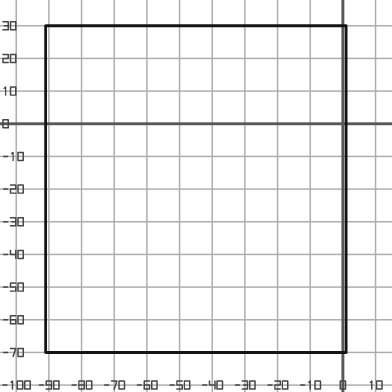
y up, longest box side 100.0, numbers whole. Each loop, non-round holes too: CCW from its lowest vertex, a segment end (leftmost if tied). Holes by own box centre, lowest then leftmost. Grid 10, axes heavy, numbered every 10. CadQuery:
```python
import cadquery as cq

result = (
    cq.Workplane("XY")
    .moveTo(-91.0, -70.0)
    .lineTo(1.0, -70.0)
    .lineTo(1.0, 30.0)
    .lineTo(-91.0, 30.0)
    .close()
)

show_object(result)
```